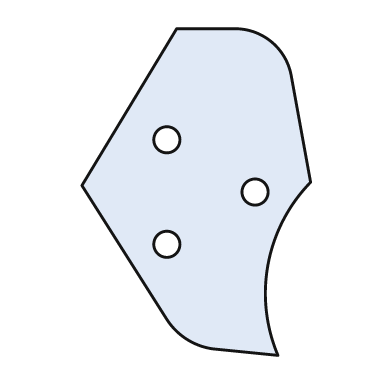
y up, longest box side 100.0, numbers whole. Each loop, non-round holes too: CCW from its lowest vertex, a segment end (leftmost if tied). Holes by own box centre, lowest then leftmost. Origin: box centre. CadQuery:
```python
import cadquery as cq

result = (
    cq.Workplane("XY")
    .moveTo(25.0, -50.0)
    .threePointArc((22.0, -22.0), (35.0, 3.0))
    .lineTo(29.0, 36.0)
    .threePointArc((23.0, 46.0), (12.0, 50.0))
    .lineTo(-6.0, 50.0)
    .lineTo(-35.0, 2.0)
    .lineTo(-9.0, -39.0)
    .threePointArc((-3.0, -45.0), (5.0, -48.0))
    .close()
    .moveTo(-9.0, -16.0)
    .circle(4.0)
    .moveTo(18.0, 0.0)
    .circle(4.0)
    .moveTo(-9.0, 16.0)
    .circle(4.0)
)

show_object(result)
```